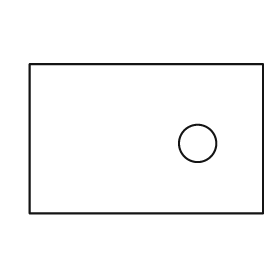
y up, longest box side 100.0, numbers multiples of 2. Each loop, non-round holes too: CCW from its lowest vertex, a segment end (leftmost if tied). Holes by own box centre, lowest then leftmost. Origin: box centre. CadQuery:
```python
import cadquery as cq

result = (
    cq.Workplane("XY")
    .moveTo(-50.0, -32.0)
    .lineTo(50.0, -32.0)
    .lineTo(50.0, 32.0)
    .lineTo(-50.0, 32.0)
    .close()
    .moveTo(22.0, -2.0)
    .circle(8.0)
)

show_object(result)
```